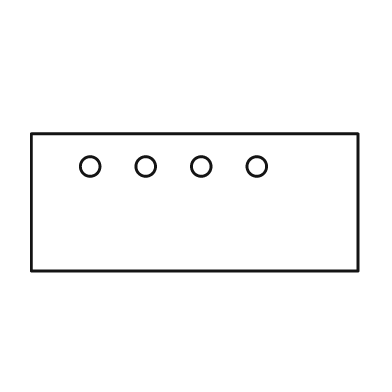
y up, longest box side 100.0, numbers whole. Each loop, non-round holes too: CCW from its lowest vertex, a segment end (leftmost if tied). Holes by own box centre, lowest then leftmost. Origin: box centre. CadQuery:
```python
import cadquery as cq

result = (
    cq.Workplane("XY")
    .moveTo(-50.0, -21.0)
    .lineTo(50.0, -21.0)
    .lineTo(50.0, 21.0)
    .lineTo(-50.0, 21.0)
    .close()
    .moveTo(-32.0, 11.0)
    .circle(3.0)
    .moveTo(-15.0, 11.0)
    .circle(3.0)
    .moveTo(2.0, 11.0)
    .circle(3.0)
    .moveTo(19.0, 11.0)
    .circle(3.0)
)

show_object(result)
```